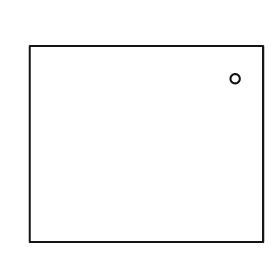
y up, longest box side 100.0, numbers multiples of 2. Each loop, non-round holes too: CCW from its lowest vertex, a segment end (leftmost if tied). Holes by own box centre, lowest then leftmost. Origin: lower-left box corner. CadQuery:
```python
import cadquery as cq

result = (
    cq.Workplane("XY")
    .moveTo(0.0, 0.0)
    .lineTo(100.0, 0.0)
    .lineTo(100.0, 84.0)
    .lineTo(0.0, 84.0)
    .close()
    .moveTo(88.0, 70.0)
    .circle(2.0)
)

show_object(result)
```